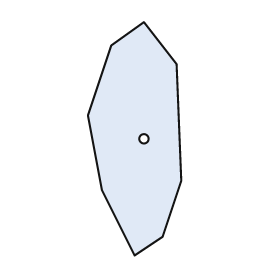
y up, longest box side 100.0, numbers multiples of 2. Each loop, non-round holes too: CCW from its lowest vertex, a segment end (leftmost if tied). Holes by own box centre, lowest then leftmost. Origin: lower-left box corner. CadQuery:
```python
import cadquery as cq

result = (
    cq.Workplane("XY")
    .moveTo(20.0, 0.0)
    .lineTo(32.0, 8.0)
    .lineTo(40.0, 32.0)
    .lineTo(38.0, 82.0)
    .lineTo(24.0, 100.0)
    .lineTo(10.0, 90.0)
    .lineTo(0.0, 60.0)
    .lineTo(6.0, 28.0)
    .close()
    .moveTo(24.0, 50.0)
    .circle(2.0)
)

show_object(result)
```